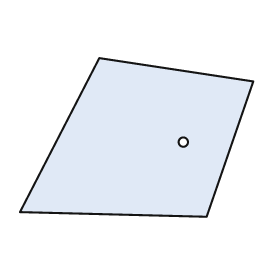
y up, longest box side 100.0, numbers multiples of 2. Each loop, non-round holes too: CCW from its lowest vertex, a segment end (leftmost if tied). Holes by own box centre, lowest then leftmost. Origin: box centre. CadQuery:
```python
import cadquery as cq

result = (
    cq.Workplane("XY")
    .moveTo(30.0, -34.0)
    .lineTo(50.0, 24.0)
    .lineTo(-16.0, 34.0)
    .lineTo(-50.0, -32.0)
    .close()
    .moveTo(20.0, -2.0)
    .circle(2.0)
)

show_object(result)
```